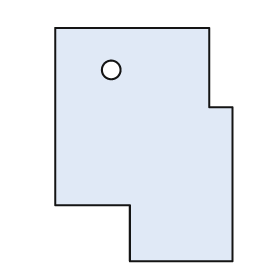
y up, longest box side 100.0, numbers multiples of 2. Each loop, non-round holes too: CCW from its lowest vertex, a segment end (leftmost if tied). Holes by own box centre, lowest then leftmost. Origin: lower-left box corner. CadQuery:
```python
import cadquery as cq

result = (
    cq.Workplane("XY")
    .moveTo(32.0, 0.0)
    .lineTo(76.0, 0.0)
    .lineTo(76.0, 66.0)
    .lineTo(66.0, 66.0)
    .lineTo(66.0, 100.0)
    .lineTo(0.0, 100.0)
    .lineTo(0.0, 24.0)
    .lineTo(32.0, 24.0)
    .close()
    .moveTo(24.0, 82.0)
    .circle(4.0)
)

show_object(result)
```